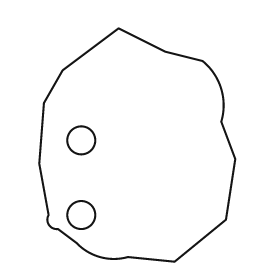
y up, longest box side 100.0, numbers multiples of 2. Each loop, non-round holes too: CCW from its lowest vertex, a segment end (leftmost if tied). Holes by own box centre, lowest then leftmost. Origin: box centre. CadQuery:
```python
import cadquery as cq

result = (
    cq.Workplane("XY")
    .moveTo(16.0, -50.0)
    .lineTo(38.0, -32.0)
    .lineTo(42.0, -6.0)
    .lineTo(36.0, 10.0)
    .threePointArc((36.0, 24.0), (28.0, 36.0))
    .lineTo(12.0, 40.0)
    .lineTo(-8.0, 50.0)
    .lineTo(-32.0, 32.0)
    .lineTo(-40.0, 18.0)
    .lineTo(-42.0, -8.0)
    .lineTo(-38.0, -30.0)
    .threePointArc((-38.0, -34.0), (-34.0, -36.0))
    .lineTo(-26.0, -42.0)
    .threePointArc((-16.0, -48.0), (-4.0, -48.0))
    .close()
    .moveTo(-24.0, -30.0)
    .circle(6.0)
    .moveTo(-24.0, 2.0)
    .circle(6.0)
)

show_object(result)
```